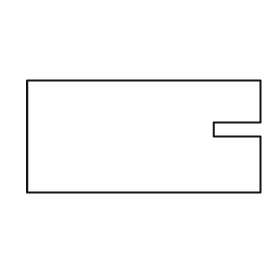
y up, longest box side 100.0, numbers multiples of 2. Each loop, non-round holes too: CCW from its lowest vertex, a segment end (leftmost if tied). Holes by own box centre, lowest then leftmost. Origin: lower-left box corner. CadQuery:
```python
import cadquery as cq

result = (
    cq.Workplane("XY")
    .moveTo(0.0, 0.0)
    .lineTo(100.0, 0.0)
    .lineTo(100.0, 24.0)
    .lineTo(80.0, 24.0)
    .lineTo(80.0, 30.0)
    .lineTo(100.0, 30.0)
    .lineTo(100.0, 48.0)
    .lineTo(0.0, 48.0)
    .close()
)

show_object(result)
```